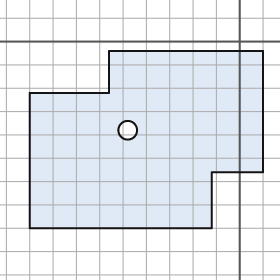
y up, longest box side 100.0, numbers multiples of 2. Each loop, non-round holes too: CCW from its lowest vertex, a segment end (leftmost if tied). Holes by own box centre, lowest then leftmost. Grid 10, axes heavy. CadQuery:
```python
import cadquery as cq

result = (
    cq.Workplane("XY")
    .moveTo(-90.0, -80.0)
    .lineTo(-12.0, -80.0)
    .lineTo(-12.0, -56.0)
    .lineTo(10.0, -56.0)
    .lineTo(10.0, -4.0)
    .lineTo(-56.0, -4.0)
    .lineTo(-56.0, -22.0)
    .lineTo(-90.0, -22.0)
    .close()
    .moveTo(-48.0, -38.0)
    .circle(4.0)
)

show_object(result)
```